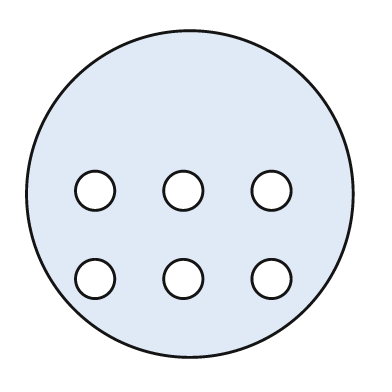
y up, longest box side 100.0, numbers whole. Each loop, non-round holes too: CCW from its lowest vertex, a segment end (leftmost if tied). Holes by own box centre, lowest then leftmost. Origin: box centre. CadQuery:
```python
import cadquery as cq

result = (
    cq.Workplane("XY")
    .moveTo(0.0, 0.0)
    .circle(50.0)
    .moveTo(-29.0, -26.0)
    .circle(6.0)
    .moveTo(-2.0, -26.0)
    .circle(6.0)
    .moveTo(25.0, -26.0)
    .circle(6.0)
    .moveTo(-29.0, 1.0)
    .circle(6.0)
    .moveTo(-2.0, 1.0)
    .circle(6.0)
    .moveTo(25.0, 1.0)
    .circle(6.0)
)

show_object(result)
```